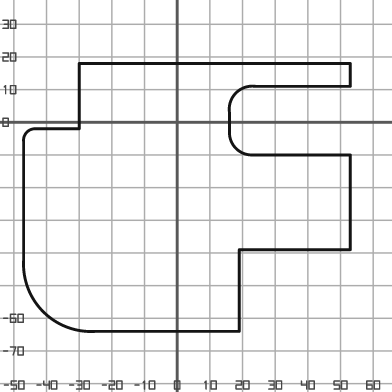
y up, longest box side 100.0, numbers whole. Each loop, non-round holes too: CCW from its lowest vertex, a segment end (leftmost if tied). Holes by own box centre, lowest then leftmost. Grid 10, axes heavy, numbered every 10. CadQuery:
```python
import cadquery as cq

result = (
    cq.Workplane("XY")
    .moveTo(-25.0, -64.0)
    .lineTo(19.0, -64.0)
    .lineTo(19.0, -39.0)
    .lineTo(53.0, -39.0)
    .lineTo(53.0, -10.0)
    .lineTo(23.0, -10.0)
    .threePointArc((18.0, -8.0), (16.0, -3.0))
    .lineTo(16.0, 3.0)
    .threePointArc((18.0, 9.0), (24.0, 11.0))
    .lineTo(53.0, 11.0)
    .lineTo(53.0, 18.0)
    .lineTo(-30.0, 18.0)
    .lineTo(-30.0, -2.0)
    .lineTo(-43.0, -2.0)
    .threePointArc((-46.0, -3.0), (-47.0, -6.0))
    .lineTo(-47.0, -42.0)
    .threePointArc((-41.0, -58.0), (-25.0, -64.0))
    .close()
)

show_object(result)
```